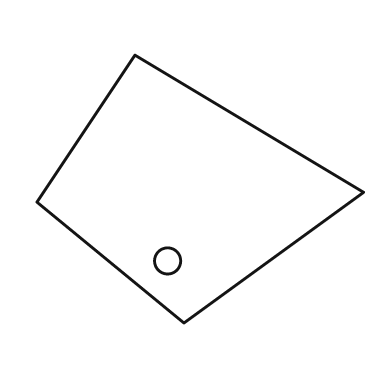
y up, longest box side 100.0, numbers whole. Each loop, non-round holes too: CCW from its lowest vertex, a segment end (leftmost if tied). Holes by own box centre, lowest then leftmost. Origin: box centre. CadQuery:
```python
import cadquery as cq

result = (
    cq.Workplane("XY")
    .moveTo(-5.0, -41.0)
    .lineTo(50.0, -1.0)
    .lineTo(-20.0, 41.0)
    .lineTo(-50.0, -4.0)
    .close()
    .moveTo(-10.0, -22.0)
    .circle(4.0)
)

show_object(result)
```